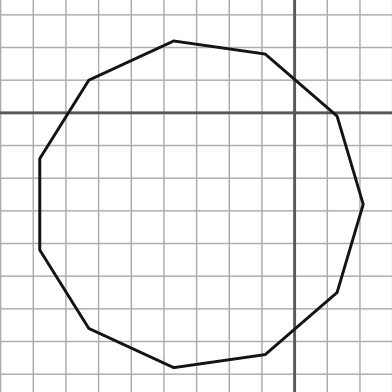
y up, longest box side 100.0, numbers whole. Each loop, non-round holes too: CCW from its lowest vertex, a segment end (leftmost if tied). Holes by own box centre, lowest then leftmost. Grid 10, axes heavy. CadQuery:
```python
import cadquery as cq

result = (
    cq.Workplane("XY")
    .moveTo(-37.0, -78.0)
    .lineTo(-9.0, -74.0)
    .lineTo(13.0, -55.0)
    .lineTo(21.0, -28.0)
    .lineTo(13.0, -1.0)
    .lineTo(-9.0, 18.0)
    .lineTo(-37.0, 22.0)
    .lineTo(-63.0, 10.0)
    .lineTo(-78.0, -14.0)
    .lineTo(-78.0, -42.0)
    .lineTo(-63.0, -66.0)
    .close()
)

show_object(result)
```